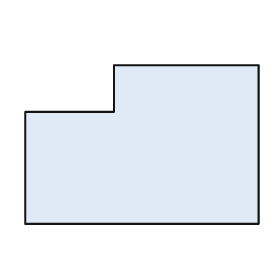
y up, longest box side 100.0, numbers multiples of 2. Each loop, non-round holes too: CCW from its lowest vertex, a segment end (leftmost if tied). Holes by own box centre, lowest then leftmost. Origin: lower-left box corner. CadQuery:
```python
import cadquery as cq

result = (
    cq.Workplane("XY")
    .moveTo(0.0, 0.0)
    .lineTo(100.0, 0.0)
    .lineTo(100.0, 68.0)
    .lineTo(38.0, 68.0)
    .lineTo(38.0, 48.0)
    .lineTo(0.0, 48.0)
    .close()
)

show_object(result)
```